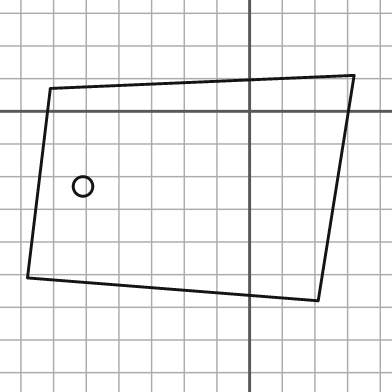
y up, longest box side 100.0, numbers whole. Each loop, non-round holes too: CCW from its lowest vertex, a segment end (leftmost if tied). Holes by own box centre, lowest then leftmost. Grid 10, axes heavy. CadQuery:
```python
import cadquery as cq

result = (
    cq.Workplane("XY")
    .moveTo(21.0, -58.0)
    .lineTo(32.0, 11.0)
    .lineTo(-61.0, 7.0)
    .lineTo(-68.0, -51.0)
    .close()
    .moveTo(-51.0, -23.0)
    .circle(3.0)
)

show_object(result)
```